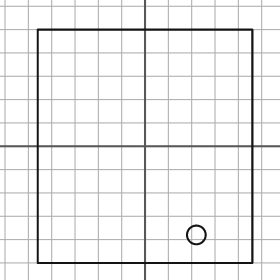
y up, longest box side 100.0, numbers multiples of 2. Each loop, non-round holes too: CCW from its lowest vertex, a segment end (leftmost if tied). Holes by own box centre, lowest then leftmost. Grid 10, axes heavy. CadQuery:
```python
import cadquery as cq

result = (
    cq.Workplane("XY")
    .moveTo(-46.0, -50.0)
    .lineTo(46.0, -50.0)
    .lineTo(46.0, 50.0)
    .lineTo(-46.0, 50.0)
    .close()
    .moveTo(22.0, -38.0)
    .circle(4.0)
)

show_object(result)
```